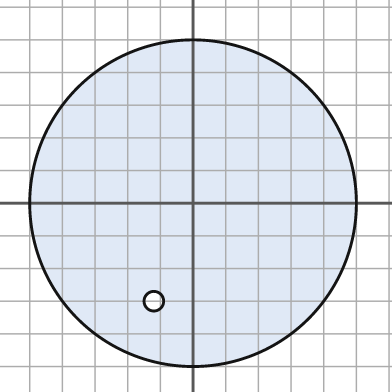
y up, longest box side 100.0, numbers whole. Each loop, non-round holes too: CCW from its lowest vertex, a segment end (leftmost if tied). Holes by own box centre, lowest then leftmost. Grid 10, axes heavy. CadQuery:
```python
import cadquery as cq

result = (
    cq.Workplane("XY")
    .moveTo(0.0, 0.0)
    .circle(50.0)
    .moveTo(-12.0, -30.0)
    .circle(3.0)
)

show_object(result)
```